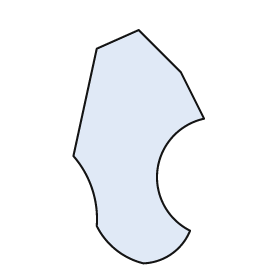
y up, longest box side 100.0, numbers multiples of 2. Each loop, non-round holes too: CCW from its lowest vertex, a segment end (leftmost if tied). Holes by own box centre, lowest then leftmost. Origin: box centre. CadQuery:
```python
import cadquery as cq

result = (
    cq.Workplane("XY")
    .moveTo(2.0, -50.0)
    .threePointArc((14.0, -46.0), (22.0, -36.0))
    .threePointArc((8.0, -10.0), (28.0, 12.0))
    .lineTo(18.0, 32.0)
    .lineTo(0.0, 50.0)
    .lineTo(-18.0, 42.0)
    .lineTo(-28.0, -4.0)
    .threePointArc((-20.0, -18.0), (-18.0, -34.0))
    .threePointArc((-10.0, -44.0), (2.0, -50.0))
    .close()
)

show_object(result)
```